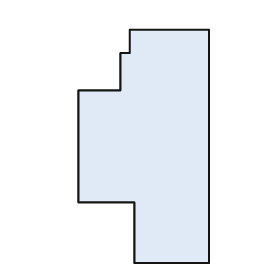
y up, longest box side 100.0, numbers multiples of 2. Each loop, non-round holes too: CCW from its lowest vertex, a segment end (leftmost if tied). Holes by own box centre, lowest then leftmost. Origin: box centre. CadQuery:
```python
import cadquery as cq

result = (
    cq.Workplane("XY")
    .moveTo(-4.0, -50.0)
    .lineTo(28.0, -50.0)
    .lineTo(28.0, 50.0)
    .lineTo(-6.0, 50.0)
    .lineTo(-6.0, 40.0)
    .lineTo(-10.0, 40.0)
    .lineTo(-10.0, 24.0)
    .lineTo(-28.0, 24.0)
    .lineTo(-28.0, -24.0)
    .lineTo(-4.0, -24.0)
    .close()
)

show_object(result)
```